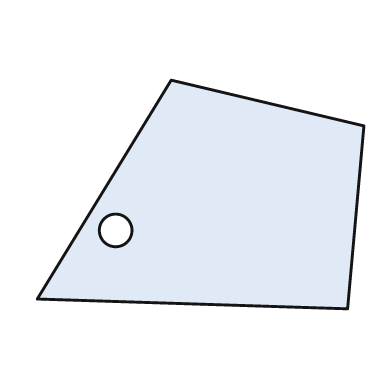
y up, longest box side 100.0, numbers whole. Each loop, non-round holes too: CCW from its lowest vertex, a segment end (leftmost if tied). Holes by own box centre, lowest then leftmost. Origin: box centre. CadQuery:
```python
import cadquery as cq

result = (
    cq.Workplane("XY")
    .moveTo(45.0, -35.0)
    .lineTo(50.0, 21.0)
    .lineTo(-9.0, 35.0)
    .lineTo(-50.0, -32.0)
    .close()
    .moveTo(-26.0, -11.0)
    .circle(5.0)
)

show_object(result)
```